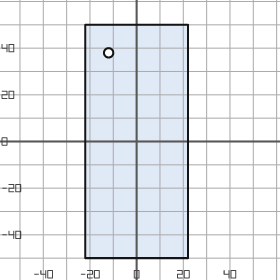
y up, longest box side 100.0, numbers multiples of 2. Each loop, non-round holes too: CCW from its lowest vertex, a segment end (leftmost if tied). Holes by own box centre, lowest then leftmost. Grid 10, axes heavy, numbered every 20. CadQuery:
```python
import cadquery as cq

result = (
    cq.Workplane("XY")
    .moveTo(-22.0, -50.0)
    .lineTo(22.0, -50.0)
    .lineTo(22.0, 50.0)
    .lineTo(-22.0, 50.0)
    .close()
    .moveTo(-12.0, 38.0)
    .circle(2.0)
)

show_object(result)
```